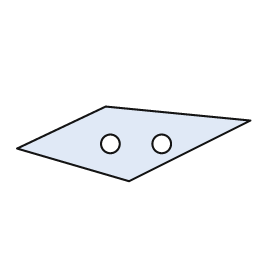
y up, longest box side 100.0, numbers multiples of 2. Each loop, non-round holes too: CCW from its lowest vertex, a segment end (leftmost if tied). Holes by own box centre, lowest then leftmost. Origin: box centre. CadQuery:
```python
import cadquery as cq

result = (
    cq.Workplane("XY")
    .moveTo(-2.0, -16.0)
    .lineTo(50.0, 10.0)
    .lineTo(-12.0, 16.0)
    .lineTo(-50.0, -2.0)
    .close()
    .moveTo(-10.0, 0.0)
    .circle(4.0)
    .moveTo(12.0, 0.0)
    .circle(4.0)
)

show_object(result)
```